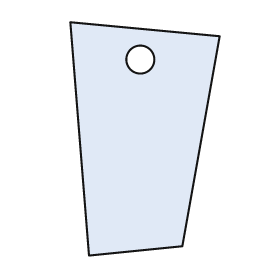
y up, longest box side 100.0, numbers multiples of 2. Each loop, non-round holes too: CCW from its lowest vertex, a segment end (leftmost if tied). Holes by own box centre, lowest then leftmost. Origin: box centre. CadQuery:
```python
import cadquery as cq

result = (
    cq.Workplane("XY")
    .moveTo(-24.0, -50.0)
    .lineTo(16.0, -46.0)
    .lineTo(32.0, 44.0)
    .lineTo(-32.0, 50.0)
    .close()
    .moveTo(-2.0, 34.0)
    .circle(6.0)
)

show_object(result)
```